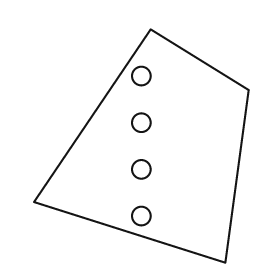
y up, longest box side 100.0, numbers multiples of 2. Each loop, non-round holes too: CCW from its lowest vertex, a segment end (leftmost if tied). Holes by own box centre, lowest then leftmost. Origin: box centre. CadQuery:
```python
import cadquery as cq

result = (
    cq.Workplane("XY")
    .moveTo(36.0, -50.0)
    .lineTo(46.0, 24.0)
    .lineTo(4.0, 50.0)
    .lineTo(-46.0, -24.0)
    .close()
    .moveTo(0.0, -30.0)
    .circle(4.0)
    .moveTo(0.0, -10.0)
    .circle(4.0)
    .moveTo(0.0, 10.0)
    .circle(4.0)
    .moveTo(0.0, 30.0)
    .circle(4.0)
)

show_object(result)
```